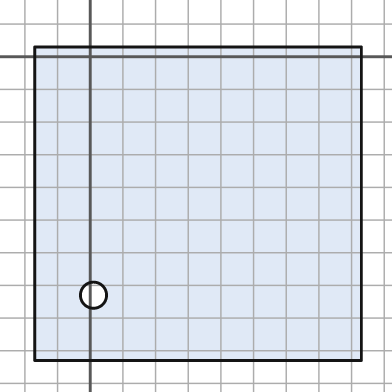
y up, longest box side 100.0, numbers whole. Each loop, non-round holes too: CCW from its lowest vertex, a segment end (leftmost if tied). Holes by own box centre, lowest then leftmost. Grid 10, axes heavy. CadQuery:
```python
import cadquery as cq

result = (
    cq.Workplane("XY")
    .moveTo(-17.0, -93.0)
    .lineTo(83.0, -93.0)
    .lineTo(83.0, 3.0)
    .lineTo(-17.0, 3.0)
    .close()
    .moveTo(1.0, -73.0)
    .circle(4.0)
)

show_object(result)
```